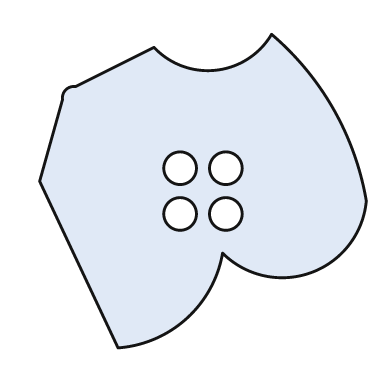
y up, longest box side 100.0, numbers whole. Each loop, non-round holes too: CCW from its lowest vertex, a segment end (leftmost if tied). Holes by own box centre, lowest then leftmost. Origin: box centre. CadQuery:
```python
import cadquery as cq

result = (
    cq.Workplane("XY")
    .moveTo(-26.0, -48.0)
    .threePointArc((-5.0, -39.0), (6.0, -19.0))
    .threePointArc((33.0, -25.0), (50.0, -3.0))
    .threePointArc((40.0, 25.0), (21.0, 48.0))
    .threePointArc((4.0, 37.0), (-15.0, 44.0))
    .lineTo(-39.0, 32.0)
    .threePointArc((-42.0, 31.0), (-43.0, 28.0))
    .lineTo(-50.0, 3.0)
    .close()
    .moveTo(-7.0, -7.0)
    .circle(5.0)
    .moveTo(7.0, -7.0)
    .circle(5.0)
    .moveTo(-7.0, 7.0)
    .circle(5.0)
    .moveTo(7.0, 7.0)
    .circle(5.0)
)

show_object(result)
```